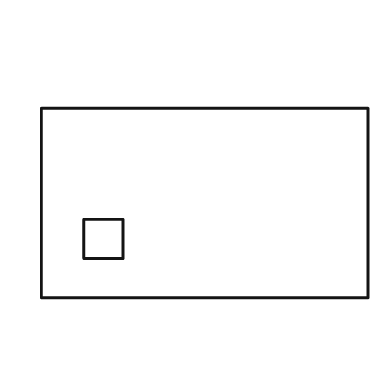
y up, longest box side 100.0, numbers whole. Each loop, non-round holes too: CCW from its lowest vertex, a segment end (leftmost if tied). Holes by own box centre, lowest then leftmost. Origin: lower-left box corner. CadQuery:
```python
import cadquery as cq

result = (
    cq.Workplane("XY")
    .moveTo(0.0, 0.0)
    .lineTo(100.0, 0.0)
    .lineTo(100.0, 58.0)
    .lineTo(0.0, 58.0)
    .close()
    .moveTo(13.0, 12.0)
    .lineTo(25.0, 12.0)
    .lineTo(25.0, 24.0)
    .lineTo(13.0, 24.0)
    .close()
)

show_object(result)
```